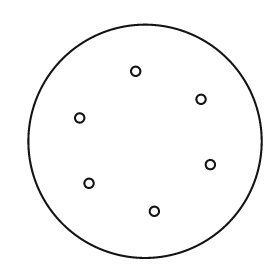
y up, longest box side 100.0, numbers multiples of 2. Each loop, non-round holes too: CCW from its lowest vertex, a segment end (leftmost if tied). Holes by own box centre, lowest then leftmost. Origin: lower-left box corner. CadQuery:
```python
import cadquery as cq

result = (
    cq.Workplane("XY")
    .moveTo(50.0, 50.0)
    .circle(50.0)
    .moveTo(54.0, 20.0)
    .circle(2.0)
    .moveTo(26.0, 32.0)
    .circle(2.0)
    .moveTo(78.0, 40.0)
    .circle(2.0)
    .moveTo(22.0, 60.0)
    .circle(2.0)
    .moveTo(74.0, 68.0)
    .circle(2.0)
    .moveTo(46.0, 80.0)
    .circle(2.0)
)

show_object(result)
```